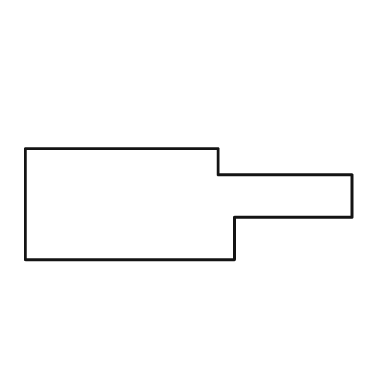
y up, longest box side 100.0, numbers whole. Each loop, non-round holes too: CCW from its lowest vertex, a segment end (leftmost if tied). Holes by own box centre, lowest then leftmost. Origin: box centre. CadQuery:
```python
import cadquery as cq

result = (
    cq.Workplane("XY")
    .moveTo(-50.0, -17.0)
    .lineTo(14.0, -17.0)
    .lineTo(14.0, -4.0)
    .lineTo(50.0, -4.0)
    .lineTo(50.0, 9.0)
    .lineTo(9.0, 9.0)
    .lineTo(9.0, 17.0)
    .lineTo(-50.0, 17.0)
    .close()
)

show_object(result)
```